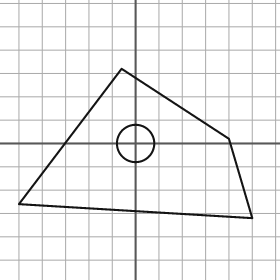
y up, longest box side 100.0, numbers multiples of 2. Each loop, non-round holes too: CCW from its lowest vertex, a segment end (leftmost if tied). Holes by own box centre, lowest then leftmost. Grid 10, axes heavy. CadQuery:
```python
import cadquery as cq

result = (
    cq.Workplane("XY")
    .moveTo(50.0, -32.0)
    .lineTo(40.0, 2.0)
    .lineTo(-6.0, 32.0)
    .lineTo(-50.0, -26.0)
    .close()
    .moveTo(0.0, 0.0)
    .circle(8.0)
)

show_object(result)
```